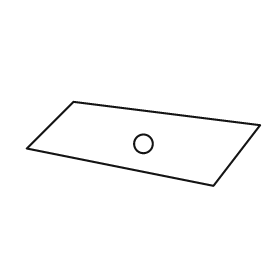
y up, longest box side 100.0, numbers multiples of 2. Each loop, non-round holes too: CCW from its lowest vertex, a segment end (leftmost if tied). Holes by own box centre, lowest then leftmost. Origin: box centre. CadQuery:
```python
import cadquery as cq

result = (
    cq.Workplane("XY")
    .moveTo(30.0, -18.0)
    .lineTo(50.0, 8.0)
    .lineTo(-30.0, 18.0)
    .lineTo(-50.0, -2.0)
    .close()
    .moveTo(0.0, 0.0)
    .circle(4.0)
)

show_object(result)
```